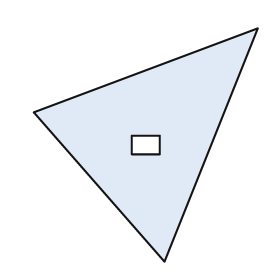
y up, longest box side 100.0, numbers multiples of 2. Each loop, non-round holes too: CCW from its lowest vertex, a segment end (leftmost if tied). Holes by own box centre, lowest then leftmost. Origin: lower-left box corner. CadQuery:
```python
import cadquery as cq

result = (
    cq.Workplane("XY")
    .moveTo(56.0, 0.0)
    .lineTo(96.0, 100.0)
    .lineTo(0.0, 64.0)
    .close()
    .moveTo(42.0, 46.0)
    .lineTo(54.0, 46.0)
    .lineTo(54.0, 54.0)
    .lineTo(42.0, 54.0)
    .close()
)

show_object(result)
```